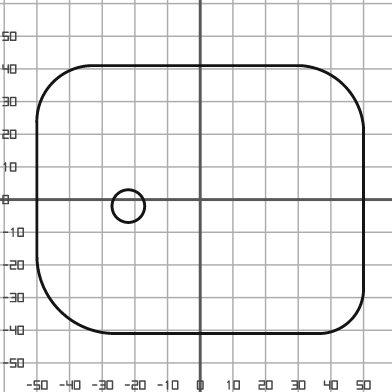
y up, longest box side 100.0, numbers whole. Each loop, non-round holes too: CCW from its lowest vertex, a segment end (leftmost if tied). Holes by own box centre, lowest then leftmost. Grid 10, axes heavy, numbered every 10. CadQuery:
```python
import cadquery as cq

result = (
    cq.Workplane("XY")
    .moveTo(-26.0, -41.0)
    .lineTo(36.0, -41.0)
    .threePointArc((46.0, -37.0), (50.0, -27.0))
    .lineTo(50.0, 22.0)
    .threePointArc((44.0, 35.0), (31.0, 41.0))
    .lineTo(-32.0, 41.0)
    .threePointArc((-45.0, 36.0), (-50.0, 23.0))
    .lineTo(-50.0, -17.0)
    .threePointArc((-43.0, -34.0), (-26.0, -41.0))
    .close()
    .moveTo(-22.0, -2.0)
    .circle(5.0)
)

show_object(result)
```